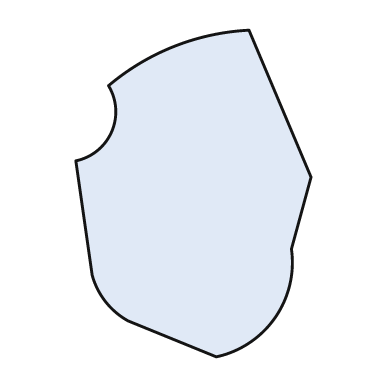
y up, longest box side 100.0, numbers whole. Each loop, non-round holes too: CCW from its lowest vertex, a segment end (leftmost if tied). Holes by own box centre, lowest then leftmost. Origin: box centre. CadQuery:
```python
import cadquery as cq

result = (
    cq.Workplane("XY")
    .moveTo(7.0, -50.0)
    .threePointArc((25.0, -38.0), (30.0, -17.0))
    .lineTo(36.0, 5.0)
    .lineTo(17.0, 50.0)
    .threePointArc((-6.0, 45.0), (-26.0, 33.0))
    .threePointArc((-25.0, 19.0), (-36.0, 10.0))
    .lineTo(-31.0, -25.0)
    .threePointArc((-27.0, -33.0), (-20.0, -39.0))
    .close()
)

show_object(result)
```